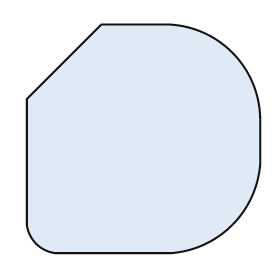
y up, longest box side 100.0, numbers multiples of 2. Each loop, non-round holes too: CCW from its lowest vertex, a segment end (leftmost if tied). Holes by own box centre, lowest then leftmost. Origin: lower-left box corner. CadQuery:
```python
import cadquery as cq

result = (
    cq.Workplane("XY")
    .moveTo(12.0, 0.0)
    .lineTo(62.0, 0.0)
    .threePointArc((88.0, 12.0), (100.0, 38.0))
    .lineTo(100.0, 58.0)
    .threePointArc((88.0, 86.0), (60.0, 98.0))
    .lineTo(32.0, 98.0)
    .lineTo(0.0, 66.0)
    .lineTo(0.0, 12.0)
    .threePointArc((4.0, 4.0), (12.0, 0.0))
    .close()
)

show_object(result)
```